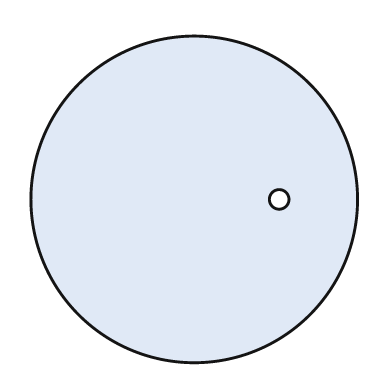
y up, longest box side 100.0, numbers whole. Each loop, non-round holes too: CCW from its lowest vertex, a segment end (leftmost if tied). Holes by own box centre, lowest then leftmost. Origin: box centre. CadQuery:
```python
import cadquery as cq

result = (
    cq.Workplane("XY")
    .moveTo(0.0, 0.0)
    .circle(50.0)
    .moveTo(26.0, 0.0)
    .circle(3.0)
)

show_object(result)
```